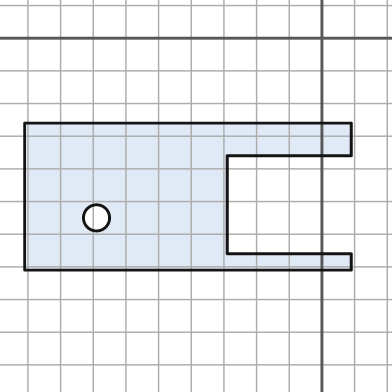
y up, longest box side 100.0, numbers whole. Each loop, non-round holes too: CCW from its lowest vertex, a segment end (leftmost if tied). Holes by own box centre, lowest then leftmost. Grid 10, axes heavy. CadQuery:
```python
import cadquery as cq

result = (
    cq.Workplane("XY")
    .moveTo(-91.0, -71.0)
    .lineTo(9.0, -71.0)
    .lineTo(9.0, -66.0)
    .lineTo(-29.0, -66.0)
    .lineTo(-29.0, -36.0)
    .lineTo(9.0, -36.0)
    .lineTo(9.0, -26.0)
    .lineTo(-91.0, -26.0)
    .close()
    .moveTo(-69.0, -55.0)
    .circle(4.0)
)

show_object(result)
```